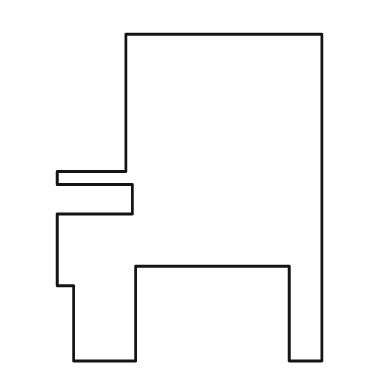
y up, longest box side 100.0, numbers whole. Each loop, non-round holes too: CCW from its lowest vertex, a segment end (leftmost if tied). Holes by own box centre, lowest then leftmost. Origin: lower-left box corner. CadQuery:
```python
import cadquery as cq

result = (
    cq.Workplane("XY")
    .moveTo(5.0, 0.0)
    .lineTo(24.0, 0.0)
    .lineTo(24.0, 29.0)
    .lineTo(71.0, 29.0)
    .lineTo(71.0, 0.0)
    .lineTo(81.0, 0.0)
    .lineTo(81.0, 100.0)
    .lineTo(21.0, 100.0)
    .lineTo(21.0, 58.0)
    .lineTo(0.0, 58.0)
    .lineTo(0.0, 54.0)
    .lineTo(23.0, 54.0)
    .lineTo(23.0, 45.0)
    .lineTo(0.0, 45.0)
    .lineTo(0.0, 23.0)
    .lineTo(5.0, 23.0)
    .close()
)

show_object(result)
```